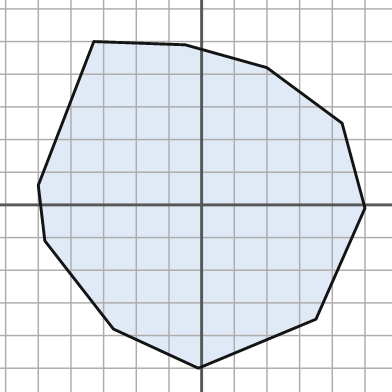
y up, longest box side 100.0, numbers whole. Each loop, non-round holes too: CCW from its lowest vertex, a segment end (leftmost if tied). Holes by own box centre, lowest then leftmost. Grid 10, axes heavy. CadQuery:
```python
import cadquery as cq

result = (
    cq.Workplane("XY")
    .moveTo(-1.0, -50.0)
    .lineTo(35.0, -35.0)
    .lineTo(50.0, -1.0)
    .lineTo(43.0, 25.0)
    .lineTo(20.0, 42.0)
    .lineTo(-5.0, 49.0)
    .lineTo(-33.0, 50.0)
    .lineTo(-50.0, 6.0)
    .lineTo(-48.0, -11.0)
    .lineTo(-27.0, -38.0)
    .close()
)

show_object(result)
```